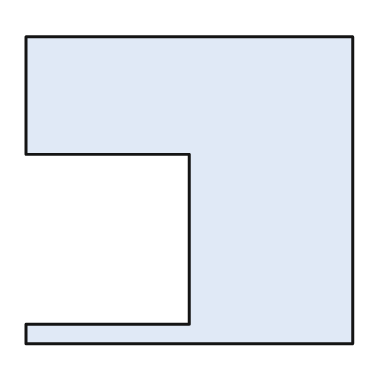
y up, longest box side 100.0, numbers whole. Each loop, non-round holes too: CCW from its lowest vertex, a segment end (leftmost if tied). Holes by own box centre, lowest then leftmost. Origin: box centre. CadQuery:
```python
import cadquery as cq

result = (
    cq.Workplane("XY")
    .moveTo(-50.0, -47.0)
    .lineTo(50.0, -47.0)
    .lineTo(50.0, 47.0)
    .lineTo(-50.0, 47.0)
    .lineTo(-50.0, 11.0)
    .lineTo(0.0, 11.0)
    .lineTo(0.0, -41.0)
    .lineTo(-50.0, -41.0)
    .close()
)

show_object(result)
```